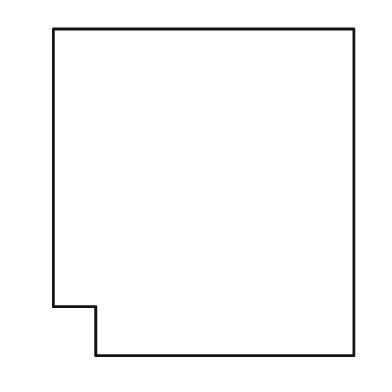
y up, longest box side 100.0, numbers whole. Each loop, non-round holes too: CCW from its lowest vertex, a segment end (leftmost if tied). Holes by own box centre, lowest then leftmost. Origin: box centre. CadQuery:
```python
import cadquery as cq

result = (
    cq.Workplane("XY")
    .moveTo(-33.0, -50.0)
    .lineTo(46.0, -50.0)
    .lineTo(46.0, 50.0)
    .lineTo(-46.0, 50.0)
    .lineTo(-46.0, -35.0)
    .lineTo(-33.0, -35.0)
    .close()
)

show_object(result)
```